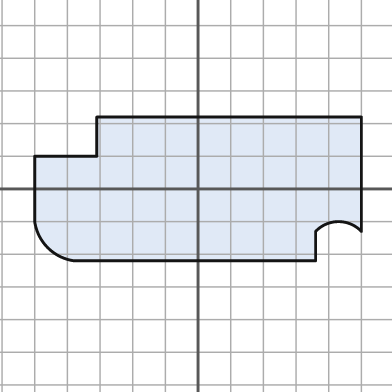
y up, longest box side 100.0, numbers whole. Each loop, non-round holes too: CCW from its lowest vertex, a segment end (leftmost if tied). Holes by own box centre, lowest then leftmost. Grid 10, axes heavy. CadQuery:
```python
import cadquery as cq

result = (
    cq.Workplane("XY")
    .moveTo(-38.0, -22.0)
    .lineTo(36.0, -22.0)
    .lineTo(36.0, -13.0)
    .threePointArc((43.0, -10.0), (50.0, -13.0))
    .lineTo(50.0, 22.0)
    .lineTo(-31.0, 22.0)
    .lineTo(-31.0, 10.0)
    .lineTo(-50.0, 10.0)
    .lineTo(-50.0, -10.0)
    .threePointArc((-46.0, -18.0), (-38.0, -22.0))
    .close()
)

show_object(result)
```